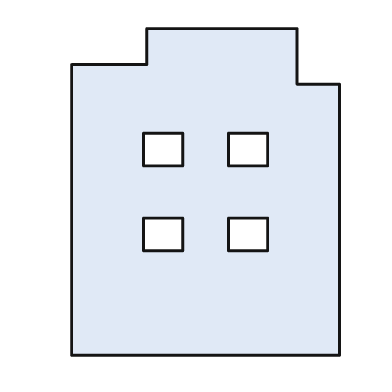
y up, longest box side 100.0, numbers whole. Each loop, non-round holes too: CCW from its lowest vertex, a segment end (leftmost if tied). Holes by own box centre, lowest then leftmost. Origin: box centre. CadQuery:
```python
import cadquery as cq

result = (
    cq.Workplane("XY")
    .moveTo(-41.0, -50.0)
    .lineTo(41.0, -50.0)
    .lineTo(41.0, 33.0)
    .lineTo(28.0, 33.0)
    .lineTo(28.0, 50.0)
    .lineTo(-18.0, 50.0)
    .lineTo(-18.0, 39.0)
    .lineTo(-41.0, 39.0)
    .close()
    .moveTo(-19.0, -18.0)
    .lineTo(-7.0, -18.0)
    .lineTo(-7.0, -8.0)
    .lineTo(-19.0, -8.0)
    .close()
    .moveTo(7.0, -18.0)
    .lineTo(19.0, -18.0)
    .lineTo(19.0, -8.0)
    .lineTo(7.0, -8.0)
    .close()
    .moveTo(-19.0, 8.0)
    .lineTo(-7.0, 8.0)
    .lineTo(-7.0, 18.0)
    .lineTo(-19.0, 18.0)
    .close()
    .moveTo(7.0, 8.0)
    .lineTo(19.0, 8.0)
    .lineTo(19.0, 18.0)
    .lineTo(7.0, 18.0)
    .close()
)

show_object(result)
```